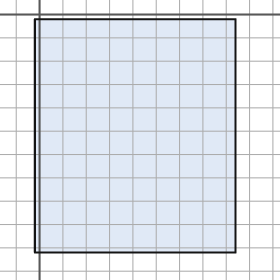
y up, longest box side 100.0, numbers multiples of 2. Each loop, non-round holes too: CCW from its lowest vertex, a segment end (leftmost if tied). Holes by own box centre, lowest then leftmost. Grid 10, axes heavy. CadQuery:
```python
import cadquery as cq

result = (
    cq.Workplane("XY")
    .moveTo(-2.0, -102.0)
    .lineTo(84.0, -102.0)
    .lineTo(84.0, -2.0)
    .lineTo(-2.0, -2.0)
    .close()
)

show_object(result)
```